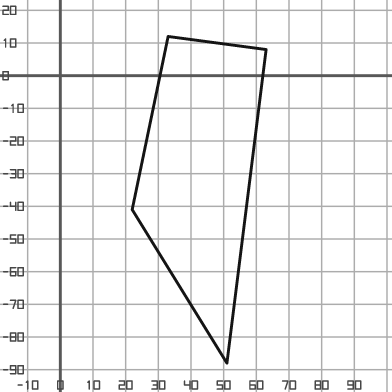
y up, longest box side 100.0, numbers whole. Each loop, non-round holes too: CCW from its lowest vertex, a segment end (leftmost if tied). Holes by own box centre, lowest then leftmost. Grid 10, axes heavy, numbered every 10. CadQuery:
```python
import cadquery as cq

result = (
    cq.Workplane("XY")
    .moveTo(51.0, -88.0)
    .lineTo(63.0, 8.0)
    .lineTo(33.0, 12.0)
    .lineTo(22.0, -41.0)
    .close()
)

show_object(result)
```